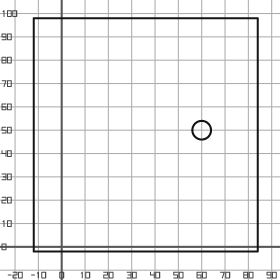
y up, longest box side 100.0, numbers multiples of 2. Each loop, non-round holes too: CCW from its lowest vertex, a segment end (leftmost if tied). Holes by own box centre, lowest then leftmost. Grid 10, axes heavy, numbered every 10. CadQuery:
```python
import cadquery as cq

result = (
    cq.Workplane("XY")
    .moveTo(-12.0, -2.0)
    .lineTo(84.0, -2.0)
    .lineTo(84.0, 98.0)
    .lineTo(-12.0, 98.0)
    .close()
    .moveTo(60.0, 50.0)
    .circle(4.0)
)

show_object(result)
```